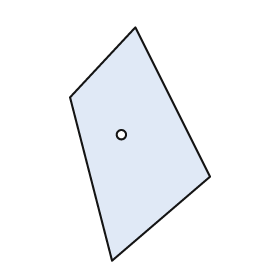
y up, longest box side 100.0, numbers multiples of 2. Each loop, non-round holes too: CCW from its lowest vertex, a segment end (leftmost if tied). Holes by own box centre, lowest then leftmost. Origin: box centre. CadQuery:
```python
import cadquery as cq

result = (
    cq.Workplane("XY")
    .moveTo(-12.0, -50.0)
    .lineTo(30.0, -14.0)
    .lineTo(-2.0, 50.0)
    .lineTo(-30.0, 20.0)
    .close()
    .moveTo(-8.0, 4.0)
    .circle(2.0)
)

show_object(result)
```